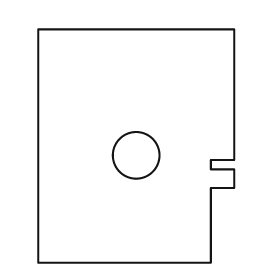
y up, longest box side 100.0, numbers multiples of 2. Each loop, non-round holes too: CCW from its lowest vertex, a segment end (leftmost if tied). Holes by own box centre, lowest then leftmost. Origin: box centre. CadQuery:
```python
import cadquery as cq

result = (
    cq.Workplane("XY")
    .moveTo(-42.0, -50.0)
    .lineTo(32.0, -50.0)
    .lineTo(32.0, -18.0)
    .lineTo(42.0, -18.0)
    .lineTo(42.0, -10.0)
    .lineTo(32.0, -10.0)
    .lineTo(32.0, -6.0)
    .lineTo(42.0, -6.0)
    .lineTo(42.0, 50.0)
    .lineTo(-42.0, 50.0)
    .close()
    .moveTo(0.0, -4.0)
    .circle(10.0)
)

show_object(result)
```